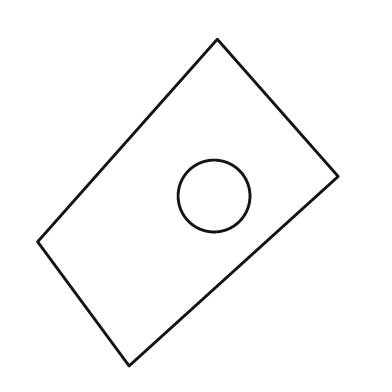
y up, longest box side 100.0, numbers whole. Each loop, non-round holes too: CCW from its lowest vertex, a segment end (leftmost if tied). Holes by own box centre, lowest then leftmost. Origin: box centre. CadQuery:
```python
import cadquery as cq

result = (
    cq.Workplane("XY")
    .moveTo(-18.0, -50.0)
    .lineTo(46.0, 8.0)
    .lineTo(9.0, 50.0)
    .lineTo(-46.0, -12.0)
    .close()
    .moveTo(8.0, 2.0)
    .circle(11.0)
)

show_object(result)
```